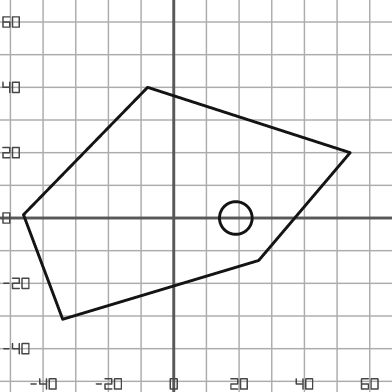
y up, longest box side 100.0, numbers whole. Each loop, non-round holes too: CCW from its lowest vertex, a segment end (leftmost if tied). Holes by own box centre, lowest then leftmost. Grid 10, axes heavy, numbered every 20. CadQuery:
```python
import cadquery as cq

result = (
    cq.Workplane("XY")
    .moveTo(-34.0, -31.0)
    .lineTo(26.0, -13.0)
    .lineTo(54.0, 20.0)
    .lineTo(-8.0, 40.0)
    .lineTo(-46.0, 1.0)
    .close()
    .moveTo(19.0, 0.0)
    .circle(5.0)
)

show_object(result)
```